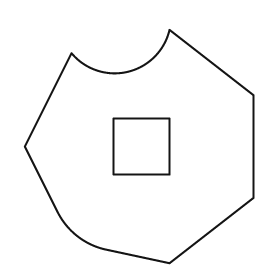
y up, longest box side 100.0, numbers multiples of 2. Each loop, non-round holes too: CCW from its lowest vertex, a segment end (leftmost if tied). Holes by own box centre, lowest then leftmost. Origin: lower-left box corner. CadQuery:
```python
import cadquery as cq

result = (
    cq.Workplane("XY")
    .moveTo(62.0, 0.0)
    .lineTo(98.0, 28.0)
    .lineTo(98.0, 72.0)
    .lineTo(62.0, 100.0)
    .threePointArc((44.0, 82.0), (20.0, 90.0))
    .lineTo(0.0, 50.0)
    .lineTo(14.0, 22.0)
    .threePointArc((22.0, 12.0), (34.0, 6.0))
    .close()
    .moveTo(38.0, 38.0)
    .lineTo(62.0, 38.0)
    .lineTo(62.0, 62.0)
    .lineTo(38.0, 62.0)
    .close()
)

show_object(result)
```